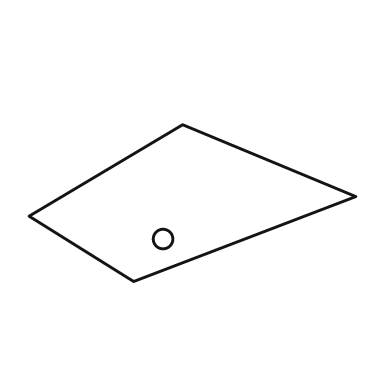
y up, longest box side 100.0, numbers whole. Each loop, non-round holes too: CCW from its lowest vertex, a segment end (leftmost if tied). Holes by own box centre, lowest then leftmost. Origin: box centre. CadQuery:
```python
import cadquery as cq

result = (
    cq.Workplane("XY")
    .moveTo(-18.0, -24.0)
    .lineTo(50.0, 2.0)
    .lineTo(-3.0, 24.0)
    .lineTo(-50.0, -4.0)
    .close()
    .moveTo(-9.0, -11.0)
    .circle(3.0)
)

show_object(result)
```